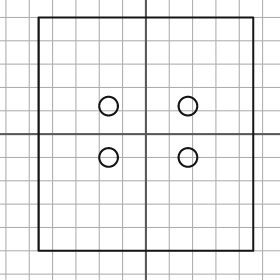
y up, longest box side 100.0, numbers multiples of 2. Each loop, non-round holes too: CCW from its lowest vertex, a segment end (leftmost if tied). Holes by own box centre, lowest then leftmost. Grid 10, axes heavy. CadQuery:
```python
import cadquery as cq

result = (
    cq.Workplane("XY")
    .moveTo(-46.0, -50.0)
    .lineTo(46.0, -50.0)
    .lineTo(46.0, 50.0)
    .lineTo(-46.0, 50.0)
    .close()
    .moveTo(-16.0, -10.0)
    .circle(4.0)
    .moveTo(18.0, -10.0)
    .circle(4.0)
    .moveTo(-16.0, 12.0)
    .circle(4.0)
    .moveTo(18.0, 12.0)
    .circle(4.0)
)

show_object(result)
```